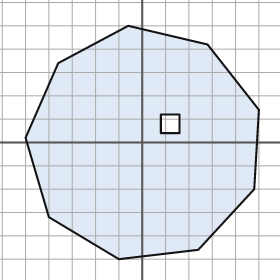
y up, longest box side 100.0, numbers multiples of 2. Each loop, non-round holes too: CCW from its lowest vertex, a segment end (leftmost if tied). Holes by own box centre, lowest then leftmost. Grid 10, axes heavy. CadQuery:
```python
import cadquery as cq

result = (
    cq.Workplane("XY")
    .moveTo(-10.0, -50.0)
    .lineTo(24.0, -46.0)
    .lineTo(48.0, -20.0)
    .lineTo(50.0, 14.0)
    .lineTo(28.0, 42.0)
    .lineTo(-6.0, 50.0)
    .lineTo(-36.0, 34.0)
    .lineTo(-50.0, 2.0)
    .lineTo(-40.0, -32.0)
    .close()
    .moveTo(8.0, 4.0)
    .lineTo(16.0, 4.0)
    .lineTo(16.0, 12.0)
    .lineTo(8.0, 12.0)
    .close()
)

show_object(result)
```